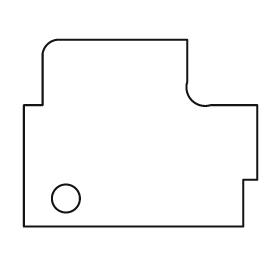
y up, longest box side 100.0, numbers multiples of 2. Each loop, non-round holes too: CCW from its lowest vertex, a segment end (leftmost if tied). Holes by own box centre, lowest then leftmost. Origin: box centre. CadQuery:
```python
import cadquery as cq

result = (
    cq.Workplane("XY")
    .moveTo(-50.0, -40.0)
    .lineTo(44.0, -40.0)
    .lineTo(44.0, -20.0)
    .lineTo(50.0, -20.0)
    .lineTo(50.0, 12.0)
    .lineTo(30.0, 12.0)
    .threePointArc((22.0, 14.0), (20.0, 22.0))
    .lineTo(20.0, 40.0)
    .lineTo(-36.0, 40.0)
    .threePointArc((-40.0, 38.0), (-42.0, 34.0))
    .lineTo(-42.0, 12.0)
    .lineTo(-50.0, 12.0)
    .close()
    .moveTo(-32.0, -28.0)
    .circle(6.0)
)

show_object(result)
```